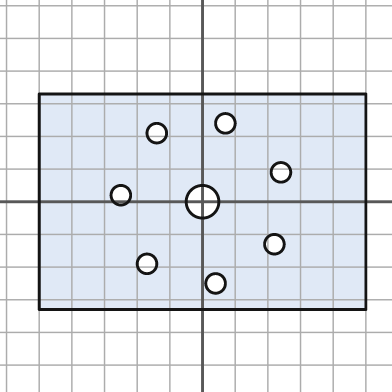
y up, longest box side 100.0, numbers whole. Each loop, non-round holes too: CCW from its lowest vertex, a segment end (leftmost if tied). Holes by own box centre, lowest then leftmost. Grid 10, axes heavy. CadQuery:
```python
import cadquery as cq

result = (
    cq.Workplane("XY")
    .moveTo(-50.0, -33.0)
    .lineTo(50.0, -33.0)
    .lineTo(50.0, 33.0)
    .lineTo(-50.0, 33.0)
    .close()
    .moveTo(4.0, -25.0)
    .circle(3.0)
    .moveTo(-17.0, -19.0)
    .circle(3.0)
    .moveTo(22.0, -13.0)
    .circle(3.0)
    .moveTo(0.0, 0.0)
    .circle(5.0)
    .moveTo(-25.0, 2.0)
    .circle(3.0)
    .moveTo(24.0, 9.0)
    .circle(3.0)
    .moveTo(-14.0, 21.0)
    .circle(3.0)
    .moveTo(7.0, 24.0)
    .circle(3.0)
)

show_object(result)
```